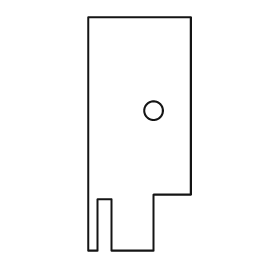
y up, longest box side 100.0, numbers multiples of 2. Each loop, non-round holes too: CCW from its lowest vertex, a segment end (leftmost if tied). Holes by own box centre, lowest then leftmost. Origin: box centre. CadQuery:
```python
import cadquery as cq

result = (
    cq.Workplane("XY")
    .moveTo(-22.0, -50.0)
    .lineTo(-18.0, -50.0)
    .lineTo(-18.0, -28.0)
    .lineTo(-12.0, -28.0)
    .lineTo(-12.0, -50.0)
    .lineTo(6.0, -50.0)
    .lineTo(6.0, -26.0)
    .lineTo(22.0, -26.0)
    .lineTo(22.0, 50.0)
    .lineTo(-22.0, 50.0)
    .close()
    .moveTo(6.0, 10.0)
    .circle(4.0)
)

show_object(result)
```